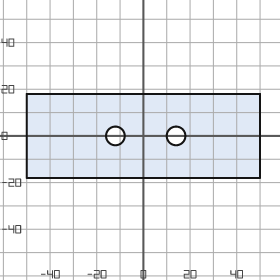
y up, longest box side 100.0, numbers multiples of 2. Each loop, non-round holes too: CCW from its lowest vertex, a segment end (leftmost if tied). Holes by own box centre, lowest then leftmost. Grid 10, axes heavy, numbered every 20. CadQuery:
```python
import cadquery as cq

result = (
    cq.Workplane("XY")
    .moveTo(-50.0, -18.0)
    .lineTo(50.0, -18.0)
    .lineTo(50.0, 18.0)
    .lineTo(-50.0, 18.0)
    .close()
    .moveTo(-12.0, 0.0)
    .circle(4.0)
    .moveTo(14.0, 0.0)
    .circle(4.0)
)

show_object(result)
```